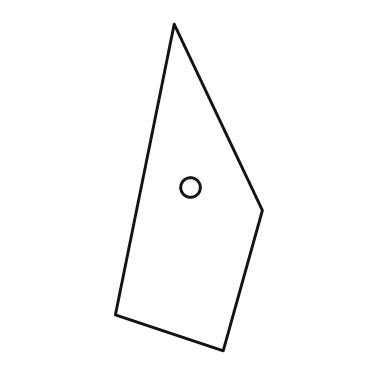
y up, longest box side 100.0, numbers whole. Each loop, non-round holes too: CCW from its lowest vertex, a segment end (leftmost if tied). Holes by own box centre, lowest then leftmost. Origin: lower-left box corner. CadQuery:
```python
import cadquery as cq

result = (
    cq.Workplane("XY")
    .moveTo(33.0, 0.0)
    .lineTo(45.0, 43.0)
    .lineTo(18.0, 100.0)
    .lineTo(0.0, 11.0)
    .close()
    .moveTo(23.0, 50.0)
    .circle(3.0)
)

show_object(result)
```